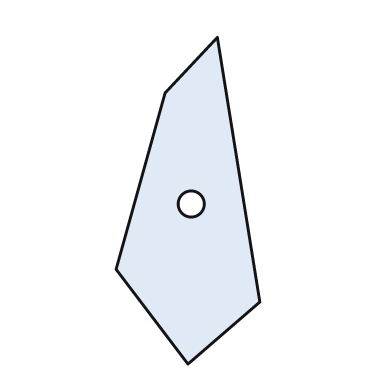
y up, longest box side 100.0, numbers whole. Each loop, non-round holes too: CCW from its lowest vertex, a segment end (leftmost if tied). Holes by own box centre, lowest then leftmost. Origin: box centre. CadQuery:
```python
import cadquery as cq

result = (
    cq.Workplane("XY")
    .moveTo(0.0, -50.0)
    .lineTo(22.0, -31.0)
    .lineTo(9.0, 50.0)
    .lineTo(-7.0, 33.0)
    .lineTo(-22.0, -21.0)
    .close()
    .moveTo(1.0, -1.0)
    .circle(4.0)
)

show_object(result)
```